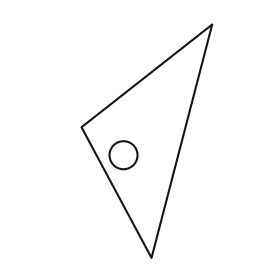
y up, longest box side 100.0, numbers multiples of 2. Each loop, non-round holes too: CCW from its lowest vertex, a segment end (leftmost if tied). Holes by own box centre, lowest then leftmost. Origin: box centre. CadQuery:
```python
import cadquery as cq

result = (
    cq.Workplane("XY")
    .moveTo(2.0, -50.0)
    .lineTo(28.0, 50.0)
    .lineTo(-28.0, 6.0)
    .close()
    .moveTo(-10.0, -6.0)
    .circle(6.0)
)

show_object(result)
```